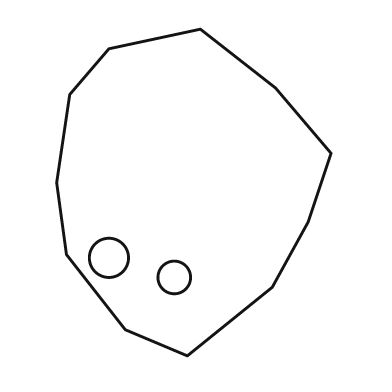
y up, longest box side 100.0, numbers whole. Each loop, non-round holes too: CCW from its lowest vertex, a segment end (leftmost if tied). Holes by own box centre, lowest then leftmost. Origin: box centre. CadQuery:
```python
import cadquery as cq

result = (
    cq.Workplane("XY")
    .moveTo(-2.0, -50.0)
    .lineTo(24.0, -29.0)
    .lineTo(35.0, -9.0)
    .lineTo(42.0, 12.0)
    .lineTo(25.0, 32.0)
    .lineTo(2.0, 50.0)
    .lineTo(-26.0, 44.0)
    .lineTo(-38.0, 30.0)
    .lineTo(-42.0, 3.0)
    .lineTo(-39.0, -19.0)
    .lineTo(-21.0, -42.0)
    .close()
    .moveTo(-6.0, -26.0)
    .circle(5.0)
    .moveTo(-26.0, -20.0)
    .circle(6.0)
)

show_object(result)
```